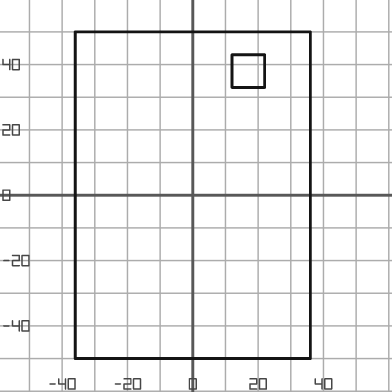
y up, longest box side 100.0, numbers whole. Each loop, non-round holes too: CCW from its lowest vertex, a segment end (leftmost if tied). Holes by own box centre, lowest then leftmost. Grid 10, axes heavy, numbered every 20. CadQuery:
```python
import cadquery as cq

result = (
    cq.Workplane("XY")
    .moveTo(-36.0, -50.0)
    .lineTo(36.0, -50.0)
    .lineTo(36.0, 50.0)
    .lineTo(-36.0, 50.0)
    .close()
    .moveTo(12.0, 33.0)
    .lineTo(22.0, 33.0)
    .lineTo(22.0, 43.0)
    .lineTo(12.0, 43.0)
    .close()
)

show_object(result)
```